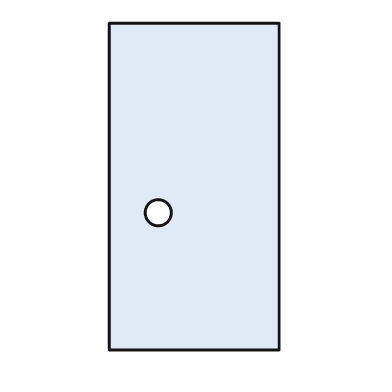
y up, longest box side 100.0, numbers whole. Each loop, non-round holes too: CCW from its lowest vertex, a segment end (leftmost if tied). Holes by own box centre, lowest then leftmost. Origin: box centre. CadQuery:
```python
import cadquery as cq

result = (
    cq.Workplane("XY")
    .moveTo(-26.0, -50.0)
    .lineTo(26.0, -50.0)
    .lineTo(26.0, 50.0)
    .lineTo(-26.0, 50.0)
    .close()
    .moveTo(-11.0, -8.0)
    .circle(4.0)
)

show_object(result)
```